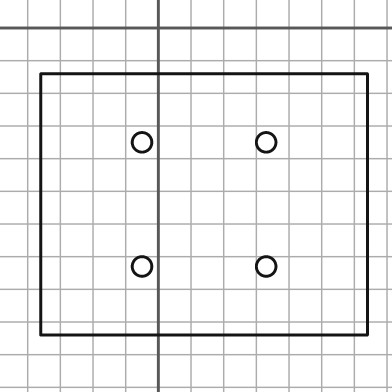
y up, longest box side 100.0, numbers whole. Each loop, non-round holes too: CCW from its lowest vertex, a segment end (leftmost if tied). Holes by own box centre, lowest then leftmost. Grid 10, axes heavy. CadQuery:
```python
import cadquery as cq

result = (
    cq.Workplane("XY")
    .moveTo(-36.0, -94.0)
    .lineTo(64.0, -94.0)
    .lineTo(64.0, -14.0)
    .lineTo(-36.0, -14.0)
    .close()
    .moveTo(-5.0, -73.0)
    .circle(3.0)
    .moveTo(33.0, -73.0)
    .circle(3.0)
    .moveTo(-5.0, -35.0)
    .circle(3.0)
    .moveTo(33.0, -35.0)
    .circle(3.0)
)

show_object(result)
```